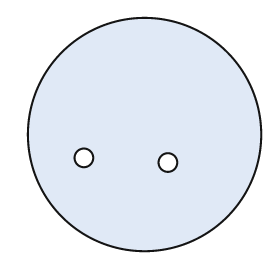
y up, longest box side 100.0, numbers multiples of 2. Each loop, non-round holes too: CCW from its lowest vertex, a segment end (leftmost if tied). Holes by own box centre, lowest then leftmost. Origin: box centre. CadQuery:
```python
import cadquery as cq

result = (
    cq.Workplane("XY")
    .moveTo(0.0, 0.0)
    .circle(50.0)
    .moveTo(10.0, -12.0)
    .circle(4.0)
    .moveTo(-26.0, -10.0)
    .circle(4.0)
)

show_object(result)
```